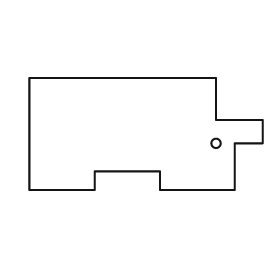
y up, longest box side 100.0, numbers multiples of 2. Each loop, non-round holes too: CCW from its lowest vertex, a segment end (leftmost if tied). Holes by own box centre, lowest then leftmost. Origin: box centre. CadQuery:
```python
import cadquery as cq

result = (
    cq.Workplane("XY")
    .moveTo(-50.0, -24.0)
    .lineTo(-22.0, -24.0)
    .lineTo(-22.0, -16.0)
    .lineTo(6.0, -16.0)
    .lineTo(6.0, -24.0)
    .lineTo(38.0, -24.0)
    .lineTo(38.0, -4.0)
    .lineTo(50.0, -4.0)
    .lineTo(50.0, 6.0)
    .lineTo(30.0, 6.0)
    .lineTo(30.0, 24.0)
    .lineTo(-50.0, 24.0)
    .close()
    .moveTo(30.0, -4.0)
    .circle(2.0)
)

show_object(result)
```